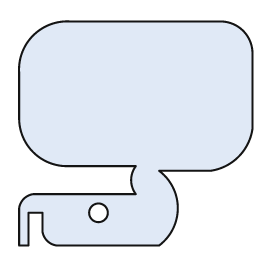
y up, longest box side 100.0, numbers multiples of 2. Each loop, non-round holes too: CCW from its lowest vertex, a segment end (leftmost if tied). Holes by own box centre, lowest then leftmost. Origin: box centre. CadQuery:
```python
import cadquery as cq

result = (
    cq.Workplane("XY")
    .moveTo(-50.0, -48.0)
    .lineTo(-46.0, -48.0)
    .lineTo(-46.0, -34.0)
    .lineTo(-40.0, -34.0)
    .lineTo(-40.0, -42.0)
    .threePointArc((-38.0, -46.0), (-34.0, -48.0))
    .lineTo(10.0, -48.0)
    .threePointArc((18.0, -32.0), (10.0, -16.0))
    .lineTo(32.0, -16.0)
    .threePointArc((44.0, -10.0), (50.0, 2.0))
    .lineTo(50.0, 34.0)
    .threePointArc((46.0, 44.0), (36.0, 48.0))
    .lineTo(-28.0, 48.0)
    .threePointArc((-44.0, 42.0), (-50.0, 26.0))
    .lineTo(-50.0, 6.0)
    .threePointArc((-44.0, -8.0), (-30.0, -14.0))
    .lineTo(0.0, -14.0)
    .threePointArc((-2.0, -20.0), (0.0, -26.0))
    .lineTo(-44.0, -26.0)
    .threePointArc((-48.0, -28.0), (-50.0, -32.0))
    .close()
    .moveTo(-16.0, -34.0)
    .circle(4.0)
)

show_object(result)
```